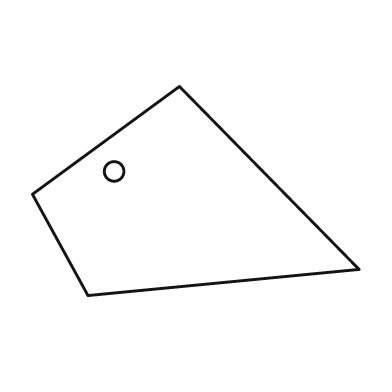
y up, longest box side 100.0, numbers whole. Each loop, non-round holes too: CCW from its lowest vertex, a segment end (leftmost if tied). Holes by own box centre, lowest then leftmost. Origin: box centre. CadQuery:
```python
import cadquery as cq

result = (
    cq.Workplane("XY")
    .moveTo(-33.0, -32.0)
    .lineTo(50.0, -24.0)
    .lineTo(-5.0, 32.0)
    .lineTo(-50.0, -1.0)
    .close()
    .moveTo(-25.0, 6.0)
    .circle(3.0)
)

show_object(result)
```